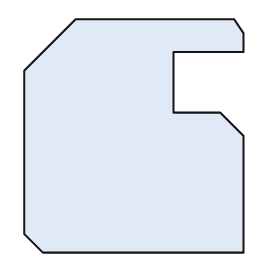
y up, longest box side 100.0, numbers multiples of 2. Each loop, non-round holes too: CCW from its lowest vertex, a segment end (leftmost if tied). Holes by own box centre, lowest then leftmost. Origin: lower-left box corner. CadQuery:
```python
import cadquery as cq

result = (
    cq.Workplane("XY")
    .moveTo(8.0, 0.0)
    .lineTo(94.0, 0.0)
    .lineTo(94.0, 50.0)
    .lineTo(84.0, 60.0)
    .lineTo(64.0, 60.0)
    .lineTo(64.0, 86.0)
    .lineTo(94.0, 86.0)
    .lineTo(94.0, 94.0)
    .lineTo(90.0, 100.0)
    .lineTo(22.0, 100.0)
    .lineTo(0.0, 78.0)
    .lineTo(0.0, 8.0)
    .close()
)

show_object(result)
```